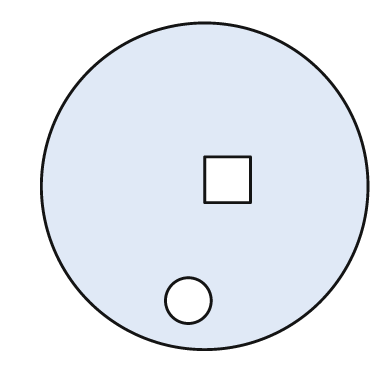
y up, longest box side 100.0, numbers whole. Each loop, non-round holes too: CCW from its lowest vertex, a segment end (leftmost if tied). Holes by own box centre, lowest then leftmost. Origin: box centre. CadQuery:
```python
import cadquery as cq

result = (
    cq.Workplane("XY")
    .moveTo(0.0, 0.0)
    .circle(50.0)
    .moveTo(-5.0, -35.0)
    .circle(7.0)
    .moveTo(0.0, -5.0)
    .lineTo(14.0, -5.0)
    .lineTo(14.0, 9.0)
    .lineTo(0.0, 9.0)
    .close()
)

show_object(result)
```